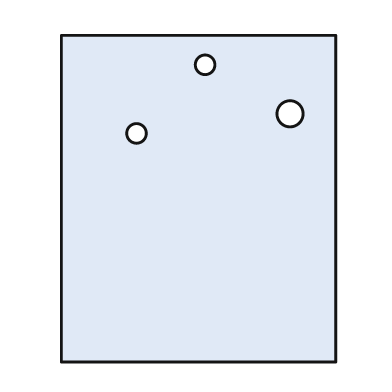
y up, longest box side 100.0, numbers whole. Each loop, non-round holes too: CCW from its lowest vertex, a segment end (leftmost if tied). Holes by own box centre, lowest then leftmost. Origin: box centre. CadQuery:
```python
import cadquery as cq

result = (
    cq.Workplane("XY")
    .moveTo(-42.0, -50.0)
    .lineTo(42.0, -50.0)
    .lineTo(42.0, 50.0)
    .lineTo(-42.0, 50.0)
    .close()
    .moveTo(-19.0, 20.0)
    .circle(3.0)
    .moveTo(28.0, 26.0)
    .circle(4.0)
    .moveTo(2.0, 41.0)
    .circle(3.0)
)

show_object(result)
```